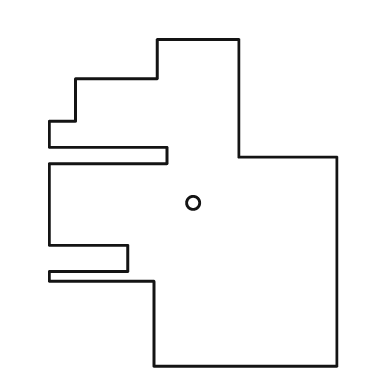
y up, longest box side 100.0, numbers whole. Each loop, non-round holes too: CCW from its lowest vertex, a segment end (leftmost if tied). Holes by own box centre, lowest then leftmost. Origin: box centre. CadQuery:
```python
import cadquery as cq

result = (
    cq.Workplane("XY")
    .moveTo(-12.0, -50.0)
    .lineTo(44.0, -50.0)
    .lineTo(44.0, 14.0)
    .lineTo(14.0, 14.0)
    .lineTo(14.0, 50.0)
    .lineTo(-11.0, 50.0)
    .lineTo(-11.0, 38.0)
    .lineTo(-36.0, 38.0)
    .lineTo(-36.0, 25.0)
    .lineTo(-44.0, 25.0)
    .lineTo(-44.0, 17.0)
    .lineTo(-8.0, 17.0)
    .lineTo(-8.0, 12.0)
    .lineTo(-44.0, 12.0)
    .lineTo(-44.0, -13.0)
    .lineTo(-20.0, -13.0)
    .lineTo(-20.0, -21.0)
    .lineTo(-44.0, -21.0)
    .lineTo(-44.0, -24.0)
    .lineTo(-12.0, -24.0)
    .close()
    .moveTo(0.0, 0.0)
    .circle(2.0)
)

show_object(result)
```